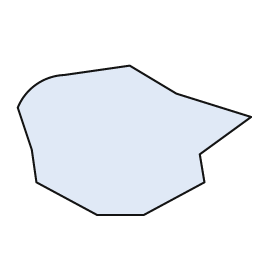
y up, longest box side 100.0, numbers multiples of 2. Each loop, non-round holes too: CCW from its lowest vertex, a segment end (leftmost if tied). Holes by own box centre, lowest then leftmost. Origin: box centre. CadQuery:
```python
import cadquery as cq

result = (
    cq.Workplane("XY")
    .moveTo(-16.0, -32.0)
    .lineTo(4.0, -32.0)
    .lineTo(30.0, -18.0)
    .lineTo(28.0, -6.0)
    .lineTo(50.0, 10.0)
    .lineTo(18.0, 20.0)
    .lineTo(-2.0, 32.0)
    .lineTo(-30.0, 28.0)
    .threePointArc((-42.0, 24.0), (-50.0, 14.0))
    .lineTo(-44.0, -4.0)
    .lineTo(-42.0, -18.0)
    .close()
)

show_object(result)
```